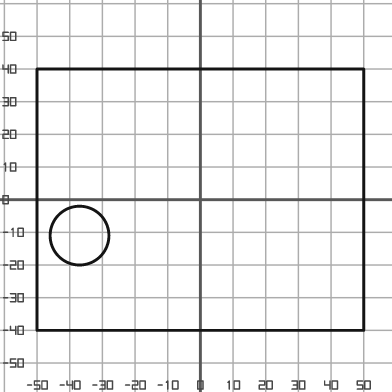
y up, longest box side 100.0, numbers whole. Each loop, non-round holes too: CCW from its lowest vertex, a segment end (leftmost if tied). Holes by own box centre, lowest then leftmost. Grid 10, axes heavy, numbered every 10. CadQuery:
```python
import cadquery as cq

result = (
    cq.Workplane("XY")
    .moveTo(-50.0, -40.0)
    .lineTo(50.0, -40.0)
    .lineTo(50.0, 40.0)
    .lineTo(-50.0, 40.0)
    .close()
    .moveTo(-37.0, -11.0)
    .circle(9.0)
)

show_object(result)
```